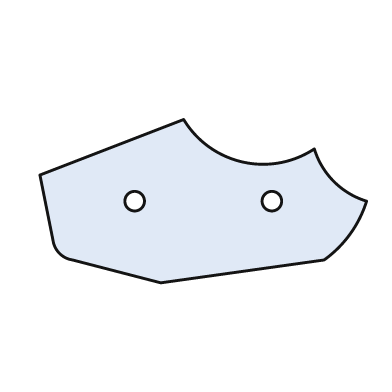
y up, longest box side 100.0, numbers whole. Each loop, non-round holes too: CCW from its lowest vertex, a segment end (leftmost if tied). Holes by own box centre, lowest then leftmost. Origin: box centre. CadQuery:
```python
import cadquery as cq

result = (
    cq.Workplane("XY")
    .moveTo(-13.0, -25.0)
    .lineTo(37.0, -18.0)
    .threePointArc((45.0, -10.0), (50.0, 0.0))
    .threePointArc((40.0, 6.0), (34.0, 16.0))
    .threePointArc((12.0, 12.0), (-6.0, 25.0))
    .lineTo(-50.0, 8.0)
    .lineTo(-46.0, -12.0)
    .threePointArc((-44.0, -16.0), (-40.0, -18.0))
    .close()
    .moveTo(-21.0, 0.0)
    .circle(3.0)
    .moveTo(21.0, 0.0)
    .circle(3.0)
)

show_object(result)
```